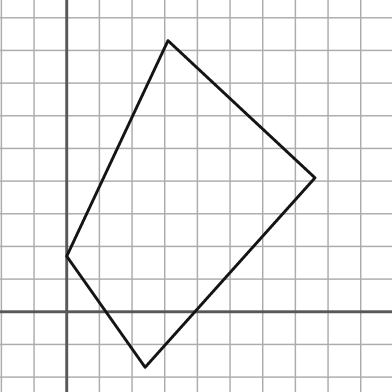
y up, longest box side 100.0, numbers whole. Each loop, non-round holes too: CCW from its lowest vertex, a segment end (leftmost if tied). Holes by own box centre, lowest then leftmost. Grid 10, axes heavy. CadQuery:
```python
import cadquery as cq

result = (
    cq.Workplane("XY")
    .moveTo(24.0, -17.0)
    .lineTo(76.0, 41.0)
    .lineTo(31.0, 83.0)
    .lineTo(0.0, 17.0)
    .close()
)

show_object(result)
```